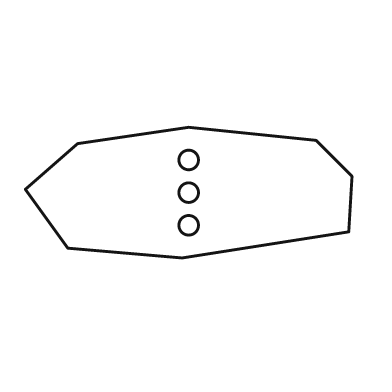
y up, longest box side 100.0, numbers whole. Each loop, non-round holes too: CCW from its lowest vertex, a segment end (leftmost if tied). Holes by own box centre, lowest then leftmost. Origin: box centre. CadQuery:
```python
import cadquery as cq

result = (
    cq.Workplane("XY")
    .moveTo(-2.0, -20.0)
    .lineTo(49.0, -12.0)
    .lineTo(50.0, 5.0)
    .lineTo(39.0, 16.0)
    .lineTo(0.0, 20.0)
    .lineTo(-34.0, 15.0)
    .lineTo(-50.0, 1.0)
    .lineTo(-37.0, -17.0)
    .close()
    .moveTo(0.0, -10.0)
    .circle(3.0)
    .moveTo(0.0, 0.0)
    .circle(3.0)
    .moveTo(0.0, 10.0)
    .circle(3.0)
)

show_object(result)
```